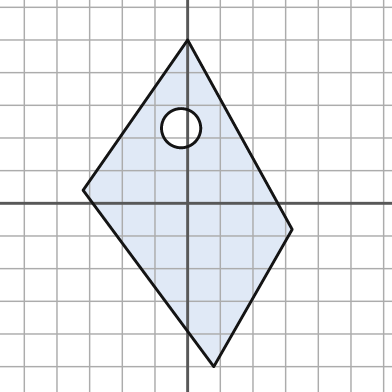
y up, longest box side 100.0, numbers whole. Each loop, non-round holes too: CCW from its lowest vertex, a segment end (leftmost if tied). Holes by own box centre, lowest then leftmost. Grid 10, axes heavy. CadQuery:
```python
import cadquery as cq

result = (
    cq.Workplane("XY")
    .moveTo(8.0, -50.0)
    .lineTo(32.0, -8.0)
    .lineTo(0.0, 50.0)
    .lineTo(-32.0, 4.0)
    .close()
    .moveTo(-2.0, 23.0)
    .circle(6.0)
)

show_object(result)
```